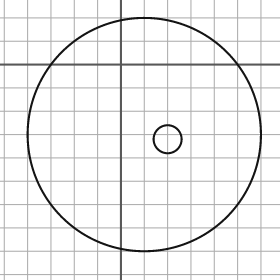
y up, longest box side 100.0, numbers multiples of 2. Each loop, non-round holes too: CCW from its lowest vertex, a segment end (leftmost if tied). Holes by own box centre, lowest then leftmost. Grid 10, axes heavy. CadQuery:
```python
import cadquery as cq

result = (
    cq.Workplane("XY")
    .moveTo(10.0, -30.0)
    .circle(50.0)
    .moveTo(20.0, -32.0)
    .circle(6.0)
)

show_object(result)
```